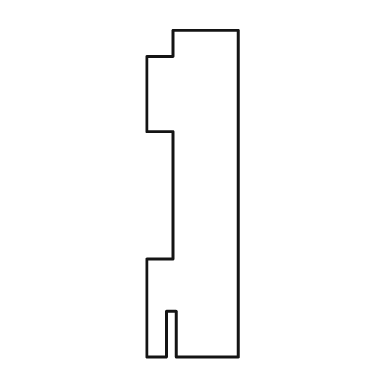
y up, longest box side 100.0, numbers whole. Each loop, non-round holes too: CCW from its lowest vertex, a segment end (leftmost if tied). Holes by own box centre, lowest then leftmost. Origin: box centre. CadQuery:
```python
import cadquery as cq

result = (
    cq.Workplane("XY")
    .moveTo(-14.0, -50.0)
    .lineTo(-8.0, -50.0)
    .lineTo(-8.0, -36.0)
    .lineTo(-5.0, -36.0)
    .lineTo(-5.0, -50.0)
    .lineTo(14.0, -50.0)
    .lineTo(14.0, 50.0)
    .lineTo(-6.0, 50.0)
    .lineTo(-6.0, 42.0)
    .lineTo(-14.0, 42.0)
    .lineTo(-14.0, 19.0)
    .lineTo(-6.0, 19.0)
    .lineTo(-6.0, -20.0)
    .lineTo(-14.0, -20.0)
    .close()
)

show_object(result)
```